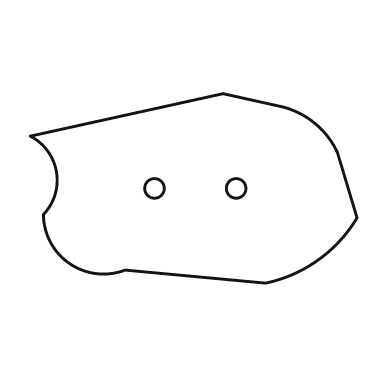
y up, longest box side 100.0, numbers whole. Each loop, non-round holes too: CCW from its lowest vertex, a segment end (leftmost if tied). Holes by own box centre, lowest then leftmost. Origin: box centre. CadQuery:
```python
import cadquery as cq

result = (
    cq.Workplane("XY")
    .moveTo(22.0, -29.0)
    .threePointArc((38.0, -22.0), (50.0, -9.0))
    .lineTo(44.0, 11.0)
    .threePointArc((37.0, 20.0), (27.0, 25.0))
    .lineTo(9.0, 29.0)
    .lineTo(-50.0, 16.0)
    .threePointArc((-42.0, 5.0), (-46.0, -8.0))
    .threePointArc((-38.0, -23.0), (-21.0, -25.0))
    .close()
    .moveTo(-12.0, 0.0)
    .circle(3.0)
    .moveTo(13.0, 0.0)
    .circle(3.0)
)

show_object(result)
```